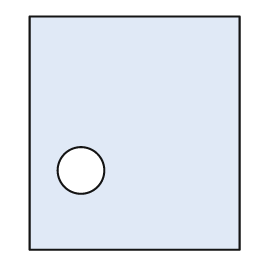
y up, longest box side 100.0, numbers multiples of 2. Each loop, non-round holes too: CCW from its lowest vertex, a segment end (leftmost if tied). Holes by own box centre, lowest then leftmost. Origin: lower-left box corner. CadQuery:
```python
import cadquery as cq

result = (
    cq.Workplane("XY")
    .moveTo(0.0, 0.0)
    .lineTo(90.0, 0.0)
    .lineTo(90.0, 100.0)
    .lineTo(0.0, 100.0)
    .close()
    .moveTo(22.0, 34.0)
    .circle(10.0)
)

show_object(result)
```